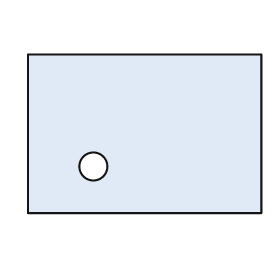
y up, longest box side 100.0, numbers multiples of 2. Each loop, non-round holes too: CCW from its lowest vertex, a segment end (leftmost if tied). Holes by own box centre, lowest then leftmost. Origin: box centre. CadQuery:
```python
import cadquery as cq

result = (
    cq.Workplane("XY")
    .moveTo(-50.0, -34.0)
    .lineTo(50.0, -34.0)
    .lineTo(50.0, 34.0)
    .lineTo(-50.0, 34.0)
    .close()
    .moveTo(-22.0, -14.0)
    .circle(6.0)
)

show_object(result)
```